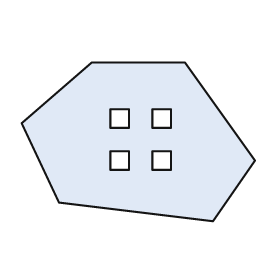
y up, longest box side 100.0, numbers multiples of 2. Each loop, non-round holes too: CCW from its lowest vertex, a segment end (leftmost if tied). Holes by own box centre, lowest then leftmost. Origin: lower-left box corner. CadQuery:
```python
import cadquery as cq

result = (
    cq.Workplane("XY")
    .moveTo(82.0, 0.0)
    .lineTo(100.0, 26.0)
    .lineTo(70.0, 68.0)
    .lineTo(30.0, 68.0)
    .lineTo(0.0, 42.0)
    .lineTo(16.0, 8.0)
    .close()
    .moveTo(38.0, 22.0)
    .lineTo(46.0, 22.0)
    .lineTo(46.0, 30.0)
    .lineTo(38.0, 30.0)
    .close()
    .moveTo(56.0, 22.0)
    .lineTo(64.0, 22.0)
    .lineTo(64.0, 30.0)
    .lineTo(56.0, 30.0)
    .close()
    .moveTo(38.0, 40.0)
    .lineTo(46.0, 40.0)
    .lineTo(46.0, 48.0)
    .lineTo(38.0, 48.0)
    .close()
    .moveTo(56.0, 40.0)
    .lineTo(64.0, 40.0)
    .lineTo(64.0, 48.0)
    .lineTo(56.0, 48.0)
    .close()
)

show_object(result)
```